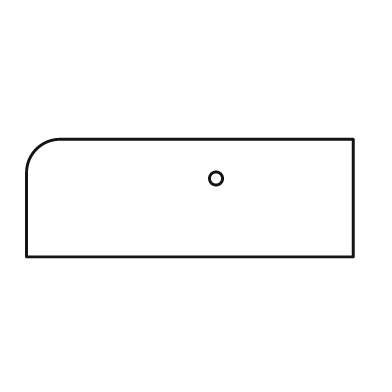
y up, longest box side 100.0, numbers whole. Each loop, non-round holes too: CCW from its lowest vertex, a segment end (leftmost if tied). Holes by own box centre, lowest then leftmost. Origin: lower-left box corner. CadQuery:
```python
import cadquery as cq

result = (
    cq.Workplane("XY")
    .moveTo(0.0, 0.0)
    .lineTo(100.0, 0.0)
    .lineTo(100.0, 36.0)
    .lineTo(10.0, 36.0)
    .threePointArc((3.0, 33.0), (0.0, 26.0))
    .close()
    .moveTo(58.0, 24.0)
    .circle(2.0)
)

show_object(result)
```